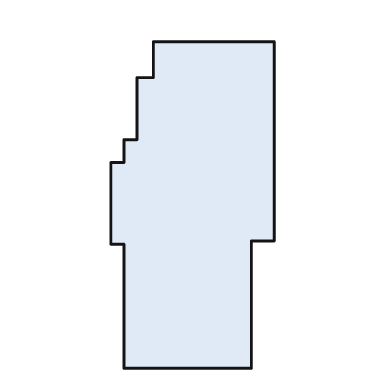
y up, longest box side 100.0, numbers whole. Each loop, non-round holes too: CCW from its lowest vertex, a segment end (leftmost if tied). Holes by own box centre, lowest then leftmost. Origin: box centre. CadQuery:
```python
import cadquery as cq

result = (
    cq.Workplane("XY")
    .moveTo(-21.0, -50.0)
    .lineTo(18.0, -50.0)
    .lineTo(18.0, -11.0)
    .lineTo(25.0, -11.0)
    .lineTo(25.0, 50.0)
    .lineTo(-12.0, 50.0)
    .lineTo(-12.0, 39.0)
    .lineTo(-17.0, 39.0)
    .lineTo(-17.0, 20.0)
    .lineTo(-21.0, 20.0)
    .lineTo(-21.0, 13.0)
    .lineTo(-25.0, 13.0)
    .lineTo(-25.0, -12.0)
    .lineTo(-21.0, -12.0)
    .close()
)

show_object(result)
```